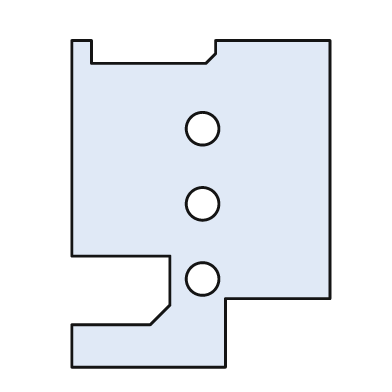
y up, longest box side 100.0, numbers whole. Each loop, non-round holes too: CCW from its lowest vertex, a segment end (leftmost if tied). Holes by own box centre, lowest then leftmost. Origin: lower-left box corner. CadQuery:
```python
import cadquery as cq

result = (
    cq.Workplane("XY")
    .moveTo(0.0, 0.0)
    .lineTo(47.0, 0.0)
    .lineTo(47.0, 21.0)
    .lineTo(79.0, 21.0)
    .lineTo(79.0, 100.0)
    .lineTo(44.0, 100.0)
    .lineTo(44.0, 96.0)
    .lineTo(41.0, 93.0)
    .lineTo(6.0, 93.0)
    .lineTo(6.0, 100.0)
    .lineTo(0.0, 100.0)
    .lineTo(0.0, 34.0)
    .lineTo(30.0, 34.0)
    .lineTo(30.0, 19.0)
    .lineTo(24.0, 13.0)
    .lineTo(0.0, 13.0)
    .close()
    .moveTo(40.0, 27.0)
    .circle(5.0)
    .moveTo(40.0, 50.0)
    .circle(5.0)
    .moveTo(40.0, 73.0)
    .circle(5.0)
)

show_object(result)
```